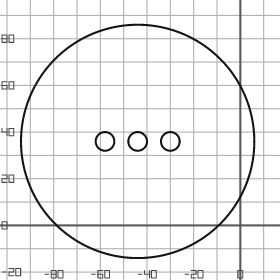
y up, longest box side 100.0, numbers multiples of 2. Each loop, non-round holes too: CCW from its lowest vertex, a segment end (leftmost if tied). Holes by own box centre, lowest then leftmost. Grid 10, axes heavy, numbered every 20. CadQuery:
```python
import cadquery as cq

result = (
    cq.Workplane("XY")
    .moveTo(-44.0, 36.0)
    .circle(50.0)
    .moveTo(-58.0, 36.0)
    .circle(4.0)
    .moveTo(-44.0, 36.0)
    .circle(4.0)
    .moveTo(-30.0, 36.0)
    .circle(4.0)
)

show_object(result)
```